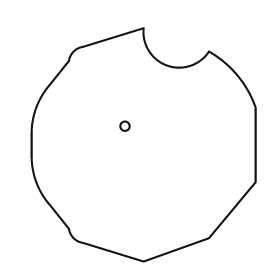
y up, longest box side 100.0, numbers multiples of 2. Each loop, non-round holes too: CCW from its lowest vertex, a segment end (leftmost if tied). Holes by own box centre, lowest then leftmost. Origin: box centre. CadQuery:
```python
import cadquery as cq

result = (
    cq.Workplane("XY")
    .moveTo(0.0, -50.0)
    .lineTo(28.0, -40.0)
    .lineTo(48.0, -16.0)
    .lineTo(48.0, 16.0)
    .threePointArc((40.0, 30.0), (28.0, 40.0))
    .threePointArc((10.0, 34.0), (0.0, 50.0))
    .lineTo(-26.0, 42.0)
    .threePointArc((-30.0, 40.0), (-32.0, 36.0))
    .lineTo(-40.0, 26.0)
    .threePointArc((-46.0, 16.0), (-48.0, 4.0))
    .lineTo(-48.0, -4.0)
    .threePointArc((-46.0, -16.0), (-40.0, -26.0))
    .lineTo(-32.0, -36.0)
    .threePointArc((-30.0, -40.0), (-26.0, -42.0))
    .close()
    .moveTo(-8.0, 8.0)
    .circle(2.0)
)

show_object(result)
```